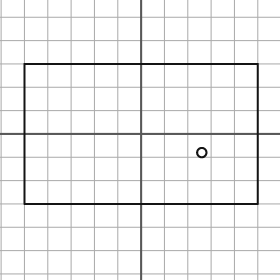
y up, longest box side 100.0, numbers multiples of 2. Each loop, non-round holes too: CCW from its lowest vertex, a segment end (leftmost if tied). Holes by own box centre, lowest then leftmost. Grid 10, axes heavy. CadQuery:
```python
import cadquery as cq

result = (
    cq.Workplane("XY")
    .moveTo(-50.0, -30.0)
    .lineTo(50.0, -30.0)
    .lineTo(50.0, 30.0)
    .lineTo(-50.0, 30.0)
    .close()
    .moveTo(26.0, -8.0)
    .circle(2.0)
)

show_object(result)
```